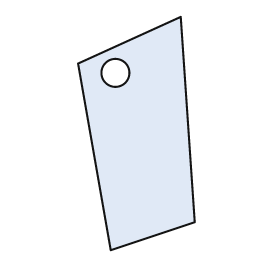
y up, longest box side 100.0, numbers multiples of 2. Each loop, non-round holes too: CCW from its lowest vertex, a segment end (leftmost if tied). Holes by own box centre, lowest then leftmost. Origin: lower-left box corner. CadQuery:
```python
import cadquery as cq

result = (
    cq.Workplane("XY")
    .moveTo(14.0, 0.0)
    .lineTo(50.0, 12.0)
    .lineTo(44.0, 100.0)
    .lineTo(0.0, 80.0)
    .close()
    .moveTo(16.0, 76.0)
    .circle(6.0)
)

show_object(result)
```